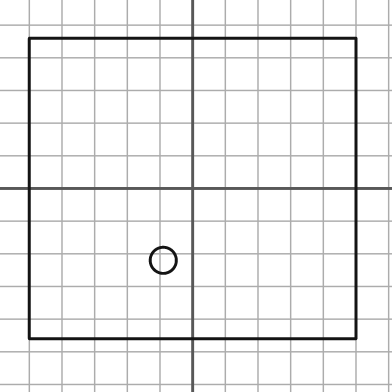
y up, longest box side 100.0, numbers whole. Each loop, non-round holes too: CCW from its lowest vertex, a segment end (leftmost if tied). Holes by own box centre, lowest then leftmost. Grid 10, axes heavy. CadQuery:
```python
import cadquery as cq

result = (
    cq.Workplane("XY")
    .moveTo(-50.0, -46.0)
    .lineTo(50.0, -46.0)
    .lineTo(50.0, 46.0)
    .lineTo(-50.0, 46.0)
    .close()
    .moveTo(-9.0, -22.0)
    .circle(4.0)
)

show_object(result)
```